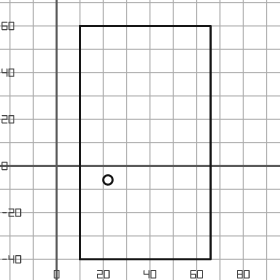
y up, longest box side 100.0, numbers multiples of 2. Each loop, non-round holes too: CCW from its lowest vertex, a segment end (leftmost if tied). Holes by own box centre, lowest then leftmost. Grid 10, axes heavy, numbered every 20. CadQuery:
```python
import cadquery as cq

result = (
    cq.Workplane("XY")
    .moveTo(10.0, -40.0)
    .lineTo(66.0, -40.0)
    .lineTo(66.0, 60.0)
    .lineTo(10.0, 60.0)
    .close()
    .moveTo(22.0, -6.0)
    .circle(2.0)
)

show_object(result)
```